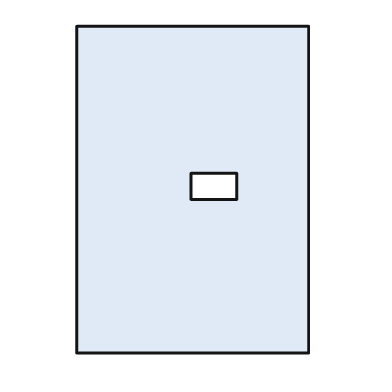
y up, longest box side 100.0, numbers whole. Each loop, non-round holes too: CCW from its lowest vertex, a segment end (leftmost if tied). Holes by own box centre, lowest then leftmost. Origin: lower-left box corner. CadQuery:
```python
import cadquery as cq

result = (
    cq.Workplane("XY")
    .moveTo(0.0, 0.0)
    .lineTo(71.0, 0.0)
    .lineTo(71.0, 100.0)
    .lineTo(0.0, 100.0)
    .close()
    .moveTo(35.0, 47.0)
    .lineTo(49.0, 47.0)
    .lineTo(49.0, 55.0)
    .lineTo(35.0, 55.0)
    .close()
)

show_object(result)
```